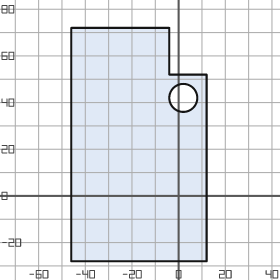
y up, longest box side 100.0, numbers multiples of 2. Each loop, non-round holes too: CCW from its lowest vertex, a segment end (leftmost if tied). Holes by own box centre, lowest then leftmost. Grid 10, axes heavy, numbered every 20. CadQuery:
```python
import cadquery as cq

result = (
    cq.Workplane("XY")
    .moveTo(-46.0, -28.0)
    .lineTo(12.0, -28.0)
    .lineTo(12.0, 52.0)
    .lineTo(-4.0, 52.0)
    .lineTo(-4.0, 72.0)
    .lineTo(-46.0, 72.0)
    .close()
    .moveTo(2.0, 42.0)
    .circle(6.0)
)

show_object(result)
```